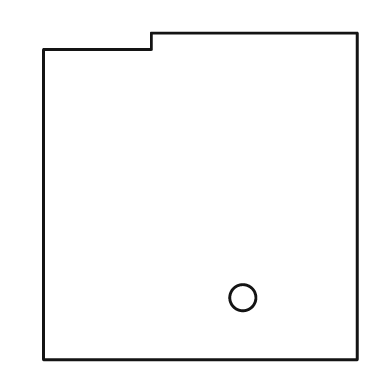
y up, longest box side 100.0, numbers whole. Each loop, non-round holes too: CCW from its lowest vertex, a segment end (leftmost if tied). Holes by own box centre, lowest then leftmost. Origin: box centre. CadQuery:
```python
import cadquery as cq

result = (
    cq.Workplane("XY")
    .moveTo(-48.0, -50.0)
    .lineTo(48.0, -50.0)
    .lineTo(48.0, 50.0)
    .lineTo(-15.0, 50.0)
    .lineTo(-15.0, 45.0)
    .lineTo(-48.0, 45.0)
    .close()
    .moveTo(13.0, -31.0)
    .circle(4.0)
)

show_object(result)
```